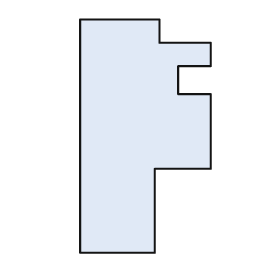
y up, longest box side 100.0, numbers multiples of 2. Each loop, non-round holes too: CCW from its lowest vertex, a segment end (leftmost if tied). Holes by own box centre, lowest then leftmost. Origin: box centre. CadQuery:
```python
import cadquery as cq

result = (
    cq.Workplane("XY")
    .moveTo(-28.0, -50.0)
    .lineTo(4.0, -50.0)
    .lineTo(4.0, -14.0)
    .lineTo(28.0, -14.0)
    .lineTo(28.0, 18.0)
    .lineTo(14.0, 18.0)
    .lineTo(14.0, 30.0)
    .lineTo(28.0, 30.0)
    .lineTo(28.0, 40.0)
    .lineTo(6.0, 40.0)
    .lineTo(6.0, 50.0)
    .lineTo(-28.0, 50.0)
    .close()
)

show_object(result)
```